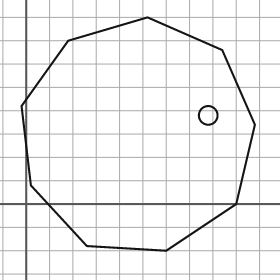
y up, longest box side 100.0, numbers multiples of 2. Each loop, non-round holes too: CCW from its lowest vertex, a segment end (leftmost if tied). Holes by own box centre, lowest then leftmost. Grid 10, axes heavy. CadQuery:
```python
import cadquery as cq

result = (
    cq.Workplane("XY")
    .moveTo(60.0, -20.0)
    .lineTo(90.0, 0.0)
    .lineTo(98.0, 34.0)
    .lineTo(84.0, 66.0)
    .lineTo(52.0, 80.0)
    .lineTo(18.0, 70.0)
    .lineTo(-2.0, 42.0)
    .lineTo(2.0, 8.0)
    .lineTo(26.0, -18.0)
    .close()
    .moveTo(78.0, 38.0)
    .circle(4.0)
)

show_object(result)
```